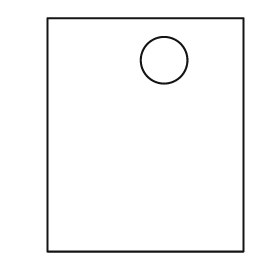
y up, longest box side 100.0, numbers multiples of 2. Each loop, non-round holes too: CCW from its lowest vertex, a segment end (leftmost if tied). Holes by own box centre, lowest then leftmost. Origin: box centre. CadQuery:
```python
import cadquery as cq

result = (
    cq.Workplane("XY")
    .moveTo(-42.0, -50.0)
    .lineTo(42.0, -50.0)
    .lineTo(42.0, 50.0)
    .lineTo(-42.0, 50.0)
    .close()
    .moveTo(8.0, 32.0)
    .circle(10.0)
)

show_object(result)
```